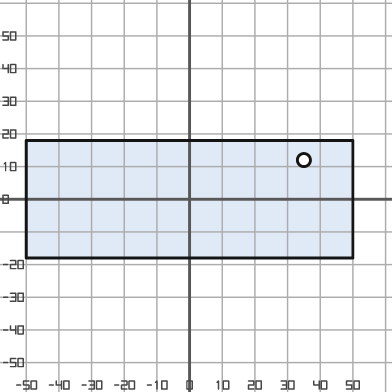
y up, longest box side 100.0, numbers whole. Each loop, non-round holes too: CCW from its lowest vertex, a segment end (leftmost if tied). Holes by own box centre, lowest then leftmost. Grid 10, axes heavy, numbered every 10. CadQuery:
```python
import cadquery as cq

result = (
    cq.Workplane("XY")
    .moveTo(-50.0, -18.0)
    .lineTo(50.0, -18.0)
    .lineTo(50.0, 18.0)
    .lineTo(-50.0, 18.0)
    .close()
    .moveTo(35.0, 12.0)
    .circle(2.0)
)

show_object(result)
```